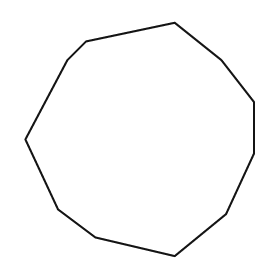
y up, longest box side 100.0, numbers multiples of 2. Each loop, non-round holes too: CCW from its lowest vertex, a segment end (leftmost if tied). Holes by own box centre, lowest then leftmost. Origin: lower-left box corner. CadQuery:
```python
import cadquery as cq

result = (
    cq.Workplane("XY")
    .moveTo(64.0, 0.0)
    .lineTo(86.0, 18.0)
    .lineTo(98.0, 44.0)
    .lineTo(98.0, 66.0)
    .lineTo(84.0, 84.0)
    .lineTo(64.0, 100.0)
    .lineTo(26.0, 92.0)
    .lineTo(18.0, 84.0)
    .lineTo(0.0, 50.0)
    .lineTo(14.0, 20.0)
    .lineTo(30.0, 8.0)
    .close()
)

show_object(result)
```